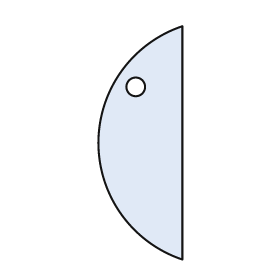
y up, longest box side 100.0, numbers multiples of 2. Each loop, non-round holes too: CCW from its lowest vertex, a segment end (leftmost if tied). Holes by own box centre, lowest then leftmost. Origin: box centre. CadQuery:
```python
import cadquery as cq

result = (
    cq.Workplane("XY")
    .moveTo(18.0, -50.0)
    .lineTo(18.0, 50.0)
    .threePointArc((-18.0, 0.0), (18.0, -50.0))
    .close()
    .moveTo(-2.0, 24.0)
    .circle(4.0)
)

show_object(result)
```